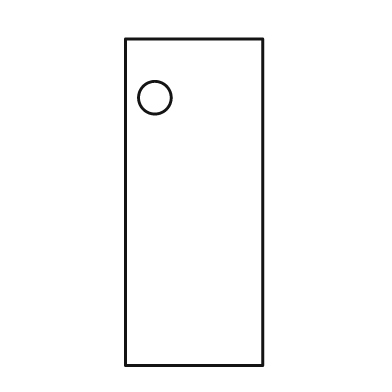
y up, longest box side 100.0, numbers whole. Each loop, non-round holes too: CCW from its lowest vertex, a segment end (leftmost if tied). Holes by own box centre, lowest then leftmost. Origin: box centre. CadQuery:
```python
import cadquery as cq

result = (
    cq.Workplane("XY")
    .moveTo(-21.0, -50.0)
    .lineTo(21.0, -50.0)
    .lineTo(21.0, 50.0)
    .lineTo(-21.0, 50.0)
    .close()
    .moveTo(-12.0, 32.0)
    .circle(5.0)
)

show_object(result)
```